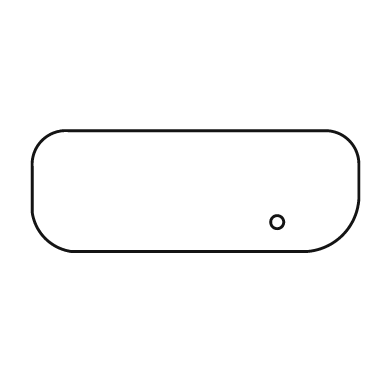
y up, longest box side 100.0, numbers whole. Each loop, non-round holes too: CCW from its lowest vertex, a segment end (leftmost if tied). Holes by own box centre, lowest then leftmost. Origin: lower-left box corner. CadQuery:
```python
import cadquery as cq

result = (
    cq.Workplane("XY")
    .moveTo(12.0, 0.0)
    .lineTo(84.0, 0.0)
    .threePointArc((95.0, 5.0), (100.0, 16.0))
    .lineTo(100.0, 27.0)
    .threePointArc((97.0, 34.0), (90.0, 37.0))
    .lineTo(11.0, 37.0)
    .threePointArc((3.0, 34.0), (0.0, 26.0))
    .lineTo(0.0, 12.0)
    .threePointArc((4.0, 4.0), (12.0, 0.0))
    .close()
    .moveTo(75.0, 9.0)
    .circle(2.0)
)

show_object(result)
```